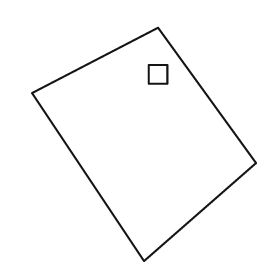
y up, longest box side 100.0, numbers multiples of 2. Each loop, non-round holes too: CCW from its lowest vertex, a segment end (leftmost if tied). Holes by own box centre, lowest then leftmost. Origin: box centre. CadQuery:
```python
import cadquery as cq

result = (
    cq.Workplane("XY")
    .moveTo(0.0, -50.0)
    .lineTo(48.0, -8.0)
    .lineTo(6.0, 50.0)
    .lineTo(-48.0, 22.0)
    .close()
    .moveTo(2.0, 26.0)
    .lineTo(10.0, 26.0)
    .lineTo(10.0, 34.0)
    .lineTo(2.0, 34.0)
    .close()
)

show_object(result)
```